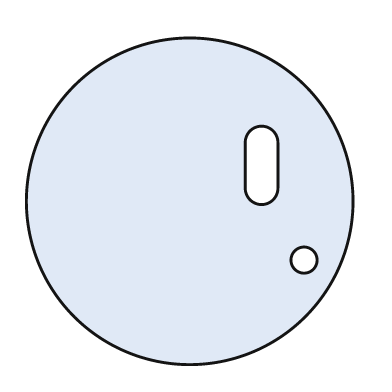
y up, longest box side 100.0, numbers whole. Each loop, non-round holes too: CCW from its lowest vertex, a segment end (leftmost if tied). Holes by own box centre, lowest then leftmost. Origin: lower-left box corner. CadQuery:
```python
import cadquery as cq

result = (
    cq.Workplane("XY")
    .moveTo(50.0, 50.0)
    .circle(50.0)
    .moveTo(85.0, 32.0)
    .circle(4.0)
    .moveTo(67.0, 54.0)
    .threePointArc((72.0, 49.0), (77.0, 54.0))
    .lineTo(77.0, 68.0)
    .threePointArc((72.0, 73.0), (67.0, 68.0))
    .close()
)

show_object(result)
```